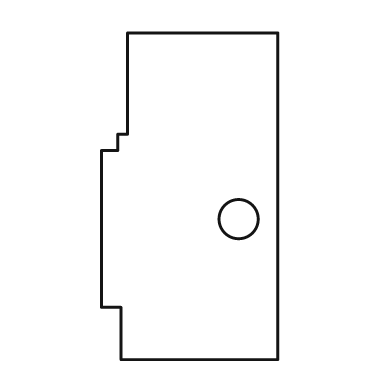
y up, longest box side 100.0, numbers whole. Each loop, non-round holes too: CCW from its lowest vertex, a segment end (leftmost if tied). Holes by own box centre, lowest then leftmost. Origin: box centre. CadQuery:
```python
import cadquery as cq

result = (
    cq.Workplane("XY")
    .moveTo(-21.0, -50.0)
    .lineTo(27.0, -50.0)
    .lineTo(27.0, 50.0)
    .lineTo(-19.0, 50.0)
    .lineTo(-19.0, 19.0)
    .lineTo(-22.0, 19.0)
    .lineTo(-22.0, 14.0)
    .lineTo(-27.0, 14.0)
    .lineTo(-27.0, -34.0)
    .lineTo(-21.0, -34.0)
    .close()
    .moveTo(15.0, -7.0)
    .circle(6.0)
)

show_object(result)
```